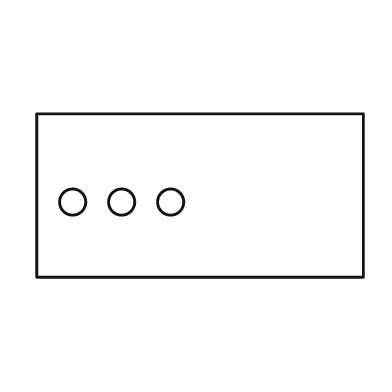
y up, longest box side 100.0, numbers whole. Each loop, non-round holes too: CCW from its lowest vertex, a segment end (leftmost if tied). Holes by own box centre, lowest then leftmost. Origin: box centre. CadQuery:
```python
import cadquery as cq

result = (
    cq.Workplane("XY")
    .moveTo(-50.0, -25.0)
    .lineTo(50.0, -25.0)
    .lineTo(50.0, 25.0)
    .lineTo(-50.0, 25.0)
    .close()
    .moveTo(-39.0, -2.0)
    .circle(4.0)
    .moveTo(-24.0, -2.0)
    .circle(4.0)
    .moveTo(-9.0, -2.0)
    .circle(4.0)
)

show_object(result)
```